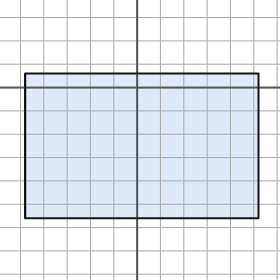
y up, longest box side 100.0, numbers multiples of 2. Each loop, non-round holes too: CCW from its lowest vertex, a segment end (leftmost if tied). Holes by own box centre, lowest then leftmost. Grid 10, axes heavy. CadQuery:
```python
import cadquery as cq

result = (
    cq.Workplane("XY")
    .moveTo(-48.0, -56.0)
    .lineTo(52.0, -56.0)
    .lineTo(52.0, 6.0)
    .lineTo(-48.0, 6.0)
    .close()
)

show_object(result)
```